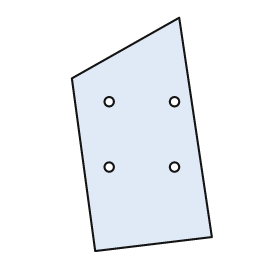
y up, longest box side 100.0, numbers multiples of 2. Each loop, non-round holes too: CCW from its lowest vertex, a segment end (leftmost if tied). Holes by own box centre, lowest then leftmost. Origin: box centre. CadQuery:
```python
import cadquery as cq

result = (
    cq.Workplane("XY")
    .moveTo(-20.0, -50.0)
    .lineTo(30.0, -44.0)
    .lineTo(16.0, 50.0)
    .lineTo(-30.0, 24.0)
    .close()
    .moveTo(-14.0, -14.0)
    .circle(2.0)
    .moveTo(14.0, -14.0)
    .circle(2.0)
    .moveTo(-14.0, 14.0)
    .circle(2.0)
    .moveTo(14.0, 14.0)
    .circle(2.0)
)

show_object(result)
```